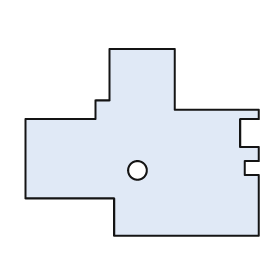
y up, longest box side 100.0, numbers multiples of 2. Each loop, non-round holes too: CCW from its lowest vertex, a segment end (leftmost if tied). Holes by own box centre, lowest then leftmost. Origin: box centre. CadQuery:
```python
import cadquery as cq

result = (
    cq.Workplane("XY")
    .moveTo(-12.0, -40.0)
    .lineTo(50.0, -40.0)
    .lineTo(50.0, -14.0)
    .lineTo(44.0, -14.0)
    .lineTo(44.0, -8.0)
    .lineTo(50.0, -8.0)
    .lineTo(50.0, -2.0)
    .lineTo(42.0, -2.0)
    .lineTo(42.0, 10.0)
    .lineTo(50.0, 10.0)
    .lineTo(50.0, 14.0)
    .lineTo(14.0, 14.0)
    .lineTo(14.0, 40.0)
    .lineTo(-14.0, 40.0)
    .lineTo(-14.0, 18.0)
    .lineTo(-20.0, 18.0)
    .lineTo(-20.0, 10.0)
    .lineTo(-50.0, 10.0)
    .lineTo(-50.0, -24.0)
    .lineTo(-12.0, -24.0)
    .close()
    .moveTo(-2.0, -12.0)
    .circle(4.0)
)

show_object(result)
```